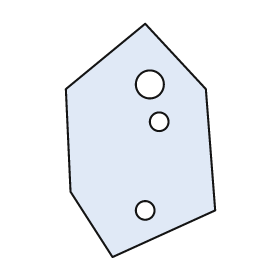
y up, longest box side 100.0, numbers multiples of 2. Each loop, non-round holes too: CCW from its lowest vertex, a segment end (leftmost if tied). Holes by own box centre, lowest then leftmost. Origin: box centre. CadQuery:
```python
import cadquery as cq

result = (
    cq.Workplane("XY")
    .moveTo(-12.0, -50.0)
    .lineTo(32.0, -30.0)
    .lineTo(28.0, 22.0)
    .lineTo(2.0, 50.0)
    .lineTo(-32.0, 22.0)
    .lineTo(-30.0, -22.0)
    .close()
    .moveTo(2.0, -30.0)
    .circle(4.0)
    .moveTo(8.0, 8.0)
    .circle(4.0)
    .moveTo(4.0, 24.0)
    .circle(6.0)
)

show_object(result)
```